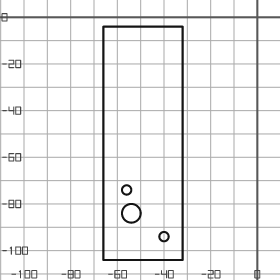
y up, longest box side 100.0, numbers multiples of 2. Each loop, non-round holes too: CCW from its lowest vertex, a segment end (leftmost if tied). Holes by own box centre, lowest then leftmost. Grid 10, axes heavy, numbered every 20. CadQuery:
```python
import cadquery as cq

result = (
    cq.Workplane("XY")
    .moveTo(-66.0, -104.0)
    .lineTo(-32.0, -104.0)
    .lineTo(-32.0, -4.0)
    .lineTo(-66.0, -4.0)
    .close()
    .moveTo(-40.0, -94.0)
    .circle(2.0)
    .moveTo(-54.0, -84.0)
    .circle(4.0)
    .moveTo(-56.0, -74.0)
    .circle(2.0)
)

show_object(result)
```